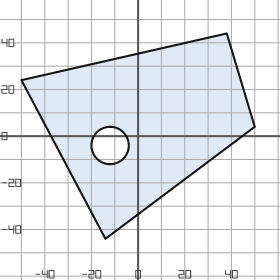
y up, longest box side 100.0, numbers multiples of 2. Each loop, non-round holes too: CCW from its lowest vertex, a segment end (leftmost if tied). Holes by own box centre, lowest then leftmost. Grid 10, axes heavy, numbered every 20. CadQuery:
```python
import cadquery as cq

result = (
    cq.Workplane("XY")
    .moveTo(-14.0, -44.0)
    .lineTo(50.0, 4.0)
    .lineTo(38.0, 44.0)
    .lineTo(-50.0, 24.0)
    .close()
    .moveTo(-12.0, -4.0)
    .circle(8.0)
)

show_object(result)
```